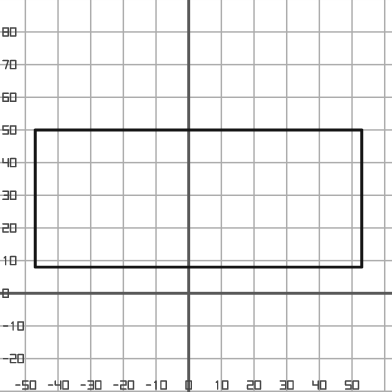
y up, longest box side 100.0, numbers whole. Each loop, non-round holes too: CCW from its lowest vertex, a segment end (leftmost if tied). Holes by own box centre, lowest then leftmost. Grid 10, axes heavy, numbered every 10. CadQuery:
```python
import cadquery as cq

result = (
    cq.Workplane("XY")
    .moveTo(-47.0, 8.0)
    .lineTo(53.0, 8.0)
    .lineTo(53.0, 50.0)
    .lineTo(-47.0, 50.0)
    .close()
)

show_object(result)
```